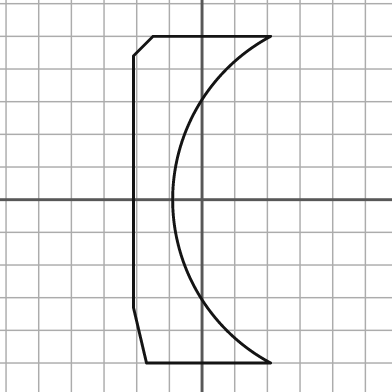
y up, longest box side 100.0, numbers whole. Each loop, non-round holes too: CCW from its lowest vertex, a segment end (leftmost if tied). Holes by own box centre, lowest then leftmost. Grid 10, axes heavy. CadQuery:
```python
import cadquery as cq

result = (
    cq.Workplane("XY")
    .moveTo(-17.0, -50.0)
    .lineTo(21.0, -50.0)
    .threePointArc((-9.0, 0.0), (21.0, 50.0))
    .lineTo(-15.0, 50.0)
    .lineTo(-21.0, 44.0)
    .lineTo(-21.0, -33.0)
    .close()
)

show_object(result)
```